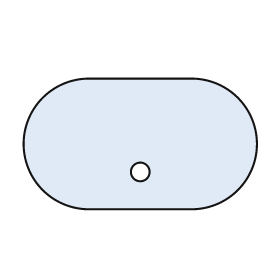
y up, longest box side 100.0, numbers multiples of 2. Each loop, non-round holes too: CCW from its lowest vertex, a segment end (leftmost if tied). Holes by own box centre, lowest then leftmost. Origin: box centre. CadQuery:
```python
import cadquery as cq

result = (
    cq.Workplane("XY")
    .moveTo(-22.0, -28.0)
    .lineTo(22.0, -28.0)
    .threePointArc((50.0, 0.0), (22.0, 28.0))
    .lineTo(-22.0, 28.0)
    .threePointArc((-50.0, 0.0), (-22.0, -28.0))
    .close()
    .moveTo(0.0, -12.0)
    .circle(4.0)
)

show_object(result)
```